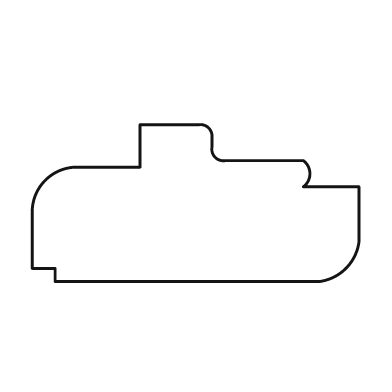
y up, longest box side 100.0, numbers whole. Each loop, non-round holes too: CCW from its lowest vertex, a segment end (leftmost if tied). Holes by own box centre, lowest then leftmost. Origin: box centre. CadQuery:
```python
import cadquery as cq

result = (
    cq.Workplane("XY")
    .moveTo(-43.0, -24.0)
    .lineTo(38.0, -24.0)
    .threePointArc((46.0, -20.0), (50.0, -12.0))
    .lineTo(50.0, 5.0)
    .lineTo(33.0, 5.0)
    .threePointArc((35.0, 9.0), (33.0, 13.0))
    .lineTo(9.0, 13.0)
    .threePointArc((6.0, 14.0), (5.0, 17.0))
    .lineTo(5.0, 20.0)
    .threePointArc((4.0, 23.0), (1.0, 24.0))
    .lineTo(-17.0, 24.0)
    .lineTo(-17.0, 11.0)
    .lineTo(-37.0, 11.0)
    .threePointArc((-46.0, 7.0), (-50.0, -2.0))
    .lineTo(-50.0, -20.0)
    .lineTo(-43.0, -20.0)
    .close()
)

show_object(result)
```